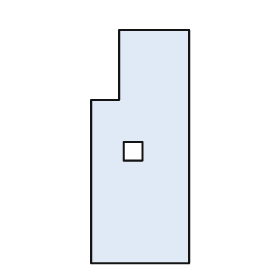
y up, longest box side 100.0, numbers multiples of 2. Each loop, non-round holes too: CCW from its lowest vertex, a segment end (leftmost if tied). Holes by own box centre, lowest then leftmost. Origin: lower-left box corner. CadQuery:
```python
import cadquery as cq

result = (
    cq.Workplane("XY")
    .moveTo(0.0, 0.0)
    .lineTo(42.0, 0.0)
    .lineTo(42.0, 100.0)
    .lineTo(12.0, 100.0)
    .lineTo(12.0, 70.0)
    .lineTo(0.0, 70.0)
    .close()
    .moveTo(14.0, 44.0)
    .lineTo(22.0, 44.0)
    .lineTo(22.0, 52.0)
    .lineTo(14.0, 52.0)
    .close()
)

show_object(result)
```